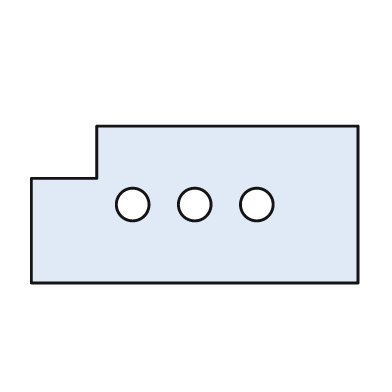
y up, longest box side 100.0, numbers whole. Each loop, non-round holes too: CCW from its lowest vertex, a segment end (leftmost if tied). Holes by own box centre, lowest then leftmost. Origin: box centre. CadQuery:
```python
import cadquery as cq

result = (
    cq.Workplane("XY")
    .moveTo(-50.0, -24.0)
    .lineTo(50.0, -24.0)
    .lineTo(50.0, 24.0)
    .lineTo(-30.0, 24.0)
    .lineTo(-30.0, 8.0)
    .lineTo(-50.0, 8.0)
    .close()
    .moveTo(-19.0, 0.0)
    .circle(5.0)
    .moveTo(0.0, 0.0)
    .circle(5.0)
    .moveTo(19.0, 0.0)
    .circle(5.0)
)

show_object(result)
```